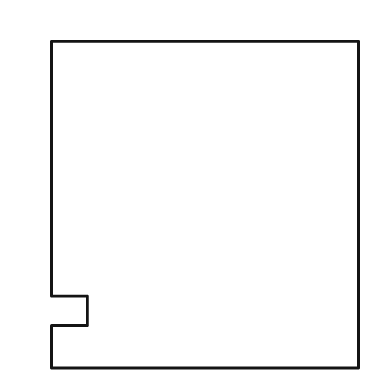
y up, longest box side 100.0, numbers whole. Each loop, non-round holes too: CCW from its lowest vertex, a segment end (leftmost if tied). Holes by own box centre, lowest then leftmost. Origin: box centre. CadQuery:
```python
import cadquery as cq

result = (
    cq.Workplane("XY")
    .moveTo(-47.0, -50.0)
    .lineTo(47.0, -50.0)
    .lineTo(47.0, 50.0)
    .lineTo(-47.0, 50.0)
    .lineTo(-47.0, -28.0)
    .lineTo(-36.0, -28.0)
    .lineTo(-36.0, -37.0)
    .lineTo(-47.0, -37.0)
    .close()
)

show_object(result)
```